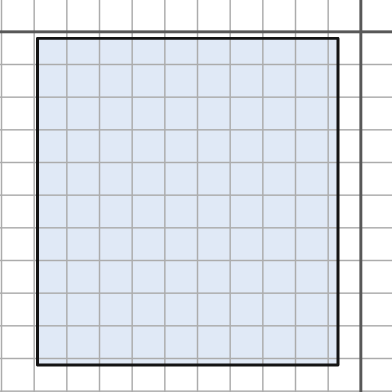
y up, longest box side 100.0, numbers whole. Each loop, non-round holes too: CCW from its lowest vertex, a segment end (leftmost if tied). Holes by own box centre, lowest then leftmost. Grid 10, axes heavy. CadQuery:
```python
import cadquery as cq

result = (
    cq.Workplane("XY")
    .moveTo(-99.0, -102.0)
    .lineTo(-7.0, -102.0)
    .lineTo(-7.0, -2.0)
    .lineTo(-99.0, -2.0)
    .close()
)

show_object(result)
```